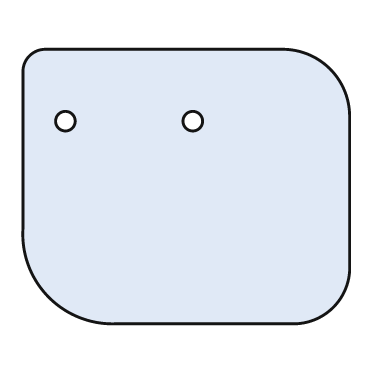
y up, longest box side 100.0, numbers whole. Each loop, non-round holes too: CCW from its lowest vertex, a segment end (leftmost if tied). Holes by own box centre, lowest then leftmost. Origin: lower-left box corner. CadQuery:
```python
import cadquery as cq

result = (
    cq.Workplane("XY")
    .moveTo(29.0, 0.0)
    .lineTo(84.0, 0.0)
    .threePointArc((95.0, 5.0), (100.0, 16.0))
    .lineTo(100.0, 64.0)
    .threePointArc((94.0, 78.0), (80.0, 84.0))
    .lineTo(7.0, 84.0)
    .threePointArc((2.0, 82.0), (0.0, 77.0))
    .lineTo(0.0, 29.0)
    .threePointArc((8.0, 8.0), (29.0, 0.0))
    .close()
    .moveTo(13.0, 62.0)
    .circle(3.0)
    .moveTo(52.0, 62.0)
    .circle(3.0)
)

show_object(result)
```